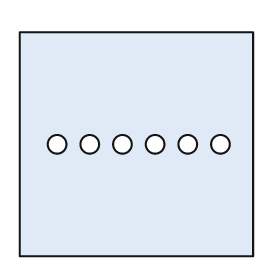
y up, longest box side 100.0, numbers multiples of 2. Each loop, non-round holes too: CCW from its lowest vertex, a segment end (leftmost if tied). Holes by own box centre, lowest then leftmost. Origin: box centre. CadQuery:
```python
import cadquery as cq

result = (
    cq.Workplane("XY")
    .moveTo(-50.0, -48.0)
    .lineTo(50.0, -48.0)
    .lineTo(50.0, 48.0)
    .lineTo(-50.0, 48.0)
    .close()
    .moveTo(-34.0, 0.0)
    .circle(4.0)
    .moveTo(-20.0, 0.0)
    .circle(4.0)
    .moveTo(-6.0, 0.0)
    .circle(4.0)
    .moveTo(8.0, 0.0)
    .circle(4.0)
    .moveTo(22.0, 0.0)
    .circle(4.0)
    .moveTo(36.0, 0.0)
    .circle(4.0)
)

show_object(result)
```